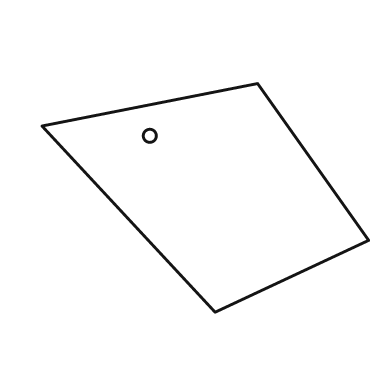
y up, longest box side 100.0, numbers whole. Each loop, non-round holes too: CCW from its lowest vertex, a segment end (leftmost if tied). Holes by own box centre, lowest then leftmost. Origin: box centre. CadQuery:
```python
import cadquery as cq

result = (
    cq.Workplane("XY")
    .moveTo(3.0, -35.0)
    .lineTo(50.0, -13.0)
    .lineTo(16.0, 35.0)
    .lineTo(-50.0, 22.0)
    .close()
    .moveTo(-17.0, 19.0)
    .circle(2.0)
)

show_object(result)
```